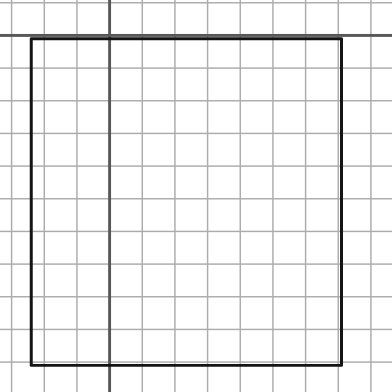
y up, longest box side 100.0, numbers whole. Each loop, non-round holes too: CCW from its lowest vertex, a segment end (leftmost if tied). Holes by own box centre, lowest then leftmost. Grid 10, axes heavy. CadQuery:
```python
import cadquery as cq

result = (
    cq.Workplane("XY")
    .moveTo(-24.0, -101.0)
    .lineTo(71.0, -101.0)
    .lineTo(71.0, -1.0)
    .lineTo(-24.0, -1.0)
    .close()
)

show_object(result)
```